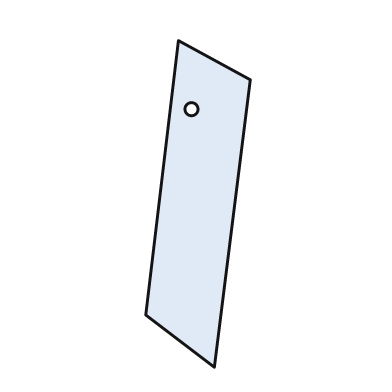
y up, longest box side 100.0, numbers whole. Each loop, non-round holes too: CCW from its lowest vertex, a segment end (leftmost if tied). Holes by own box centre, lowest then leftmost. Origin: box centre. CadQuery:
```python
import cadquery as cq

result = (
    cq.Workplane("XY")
    .moveTo(5.0, -50.0)
    .lineTo(16.0, 38.0)
    .lineTo(-6.0, 50.0)
    .lineTo(-16.0, -34.0)
    .close()
    .moveTo(-2.0, 29.0)
    .circle(2.0)
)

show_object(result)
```